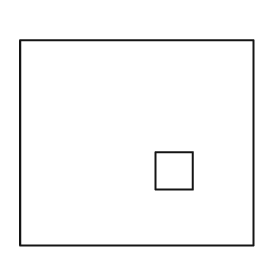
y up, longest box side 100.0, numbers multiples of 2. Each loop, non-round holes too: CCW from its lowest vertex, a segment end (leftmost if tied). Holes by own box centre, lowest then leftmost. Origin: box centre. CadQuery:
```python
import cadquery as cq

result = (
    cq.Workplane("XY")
    .moveTo(-50.0, -44.0)
    .lineTo(50.0, -44.0)
    .lineTo(50.0, 44.0)
    .lineTo(-50.0, 44.0)
    .close()
    .moveTo(8.0, -20.0)
    .lineTo(24.0, -20.0)
    .lineTo(24.0, -4.0)
    .lineTo(8.0, -4.0)
    .close()
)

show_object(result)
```